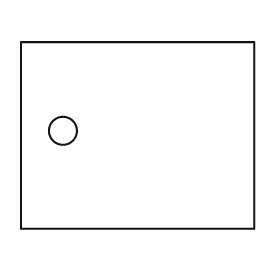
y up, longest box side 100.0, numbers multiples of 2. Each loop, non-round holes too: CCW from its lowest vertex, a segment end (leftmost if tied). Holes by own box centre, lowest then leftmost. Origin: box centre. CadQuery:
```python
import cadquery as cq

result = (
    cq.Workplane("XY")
    .moveTo(-50.0, -40.0)
    .lineTo(50.0, -40.0)
    .lineTo(50.0, 40.0)
    .lineTo(-50.0, 40.0)
    .close()
    .moveTo(-32.0, 2.0)
    .circle(6.0)
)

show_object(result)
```